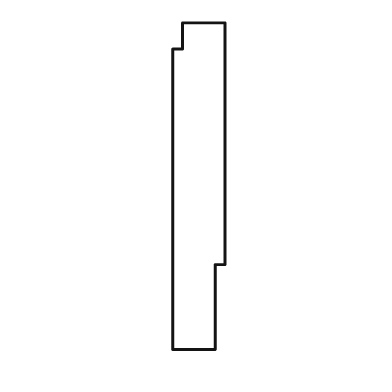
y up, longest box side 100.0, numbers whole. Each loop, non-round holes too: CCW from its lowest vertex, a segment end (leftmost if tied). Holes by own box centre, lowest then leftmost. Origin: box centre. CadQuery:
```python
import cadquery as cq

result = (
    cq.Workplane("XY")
    .moveTo(-8.0, -50.0)
    .lineTo(5.0, -50.0)
    .lineTo(5.0, -24.0)
    .lineTo(8.0, -24.0)
    .lineTo(8.0, 50.0)
    .lineTo(-5.0, 50.0)
    .lineTo(-5.0, 42.0)
    .lineTo(-8.0, 42.0)
    .close()
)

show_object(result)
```